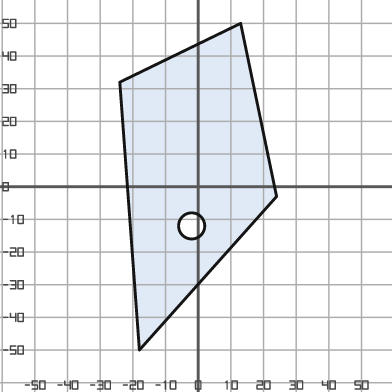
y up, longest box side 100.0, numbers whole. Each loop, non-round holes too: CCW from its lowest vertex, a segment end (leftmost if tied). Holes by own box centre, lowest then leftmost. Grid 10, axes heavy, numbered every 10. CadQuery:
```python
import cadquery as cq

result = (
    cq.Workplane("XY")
    .moveTo(-18.0, -50.0)
    .lineTo(24.0, -3.0)
    .lineTo(13.0, 50.0)
    .lineTo(-24.0, 32.0)
    .close()
    .moveTo(-2.0, -12.0)
    .circle(4.0)
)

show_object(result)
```